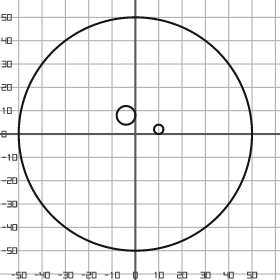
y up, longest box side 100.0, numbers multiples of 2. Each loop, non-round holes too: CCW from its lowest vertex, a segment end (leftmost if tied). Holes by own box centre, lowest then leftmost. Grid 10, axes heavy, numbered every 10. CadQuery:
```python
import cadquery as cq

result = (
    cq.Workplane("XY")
    .moveTo(0.0, 0.0)
    .circle(50.0)
    .moveTo(10.0, 2.0)
    .circle(2.0)
    .moveTo(-4.0, 8.0)
    .circle(4.0)
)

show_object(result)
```